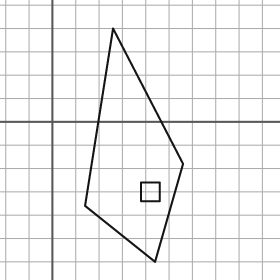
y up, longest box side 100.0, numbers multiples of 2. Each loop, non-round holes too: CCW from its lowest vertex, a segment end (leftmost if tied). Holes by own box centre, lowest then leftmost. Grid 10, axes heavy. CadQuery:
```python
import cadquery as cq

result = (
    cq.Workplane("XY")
    .moveTo(44.0, -60.0)
    .lineTo(56.0, -18.0)
    .lineTo(26.0, 40.0)
    .lineTo(14.0, -36.0)
    .close()
    .moveTo(38.0, -34.0)
    .lineTo(46.0, -34.0)
    .lineTo(46.0, -26.0)
    .lineTo(38.0, -26.0)
    .close()
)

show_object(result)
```